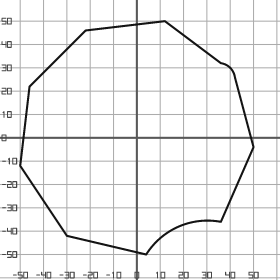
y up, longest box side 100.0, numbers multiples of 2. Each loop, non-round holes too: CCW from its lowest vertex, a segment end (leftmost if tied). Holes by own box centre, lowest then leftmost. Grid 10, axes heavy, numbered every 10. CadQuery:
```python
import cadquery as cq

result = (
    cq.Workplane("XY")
    .moveTo(4.0, -50.0)
    .threePointArc((18.0, -38.0), (36.0, -36.0))
    .lineTo(50.0, -4.0)
    .lineTo(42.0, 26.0)
    .threePointArc((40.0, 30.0), (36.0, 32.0))
    .lineTo(12.0, 50.0)
    .lineTo(-22.0, 46.0)
    .lineTo(-46.0, 22.0)
    .lineTo(-50.0, -12.0)
    .lineTo(-30.0, -42.0)
    .close()
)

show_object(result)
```